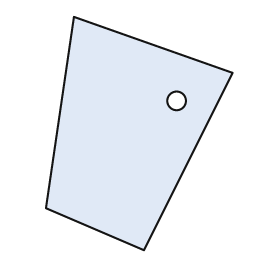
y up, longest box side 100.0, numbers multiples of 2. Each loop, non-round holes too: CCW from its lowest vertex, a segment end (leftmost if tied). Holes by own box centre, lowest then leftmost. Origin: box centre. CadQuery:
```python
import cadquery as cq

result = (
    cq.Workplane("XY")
    .moveTo(2.0, -50.0)
    .lineTo(40.0, 26.0)
    .lineTo(-28.0, 50.0)
    .lineTo(-40.0, -32.0)
    .close()
    .moveTo(16.0, 14.0)
    .circle(4.0)
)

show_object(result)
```